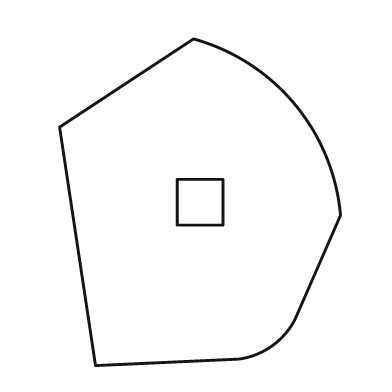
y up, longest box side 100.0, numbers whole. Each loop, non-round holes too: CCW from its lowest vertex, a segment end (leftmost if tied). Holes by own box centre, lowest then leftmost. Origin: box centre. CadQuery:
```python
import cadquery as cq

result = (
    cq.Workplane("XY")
    .moveTo(-32.0, -50.0)
    .lineTo(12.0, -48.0)
    .threePointArc((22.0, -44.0), (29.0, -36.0))
    .lineTo(43.0, -4.0)
    .threePointArc((29.0, 30.0), (-2.0, 50.0))
    .lineTo(-43.0, 23.0)
    .close()
    .moveTo(-7.0, -7.0)
    .lineTo(7.0, -7.0)
    .lineTo(7.0, 7.0)
    .lineTo(-7.0, 7.0)
    .close()
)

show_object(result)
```